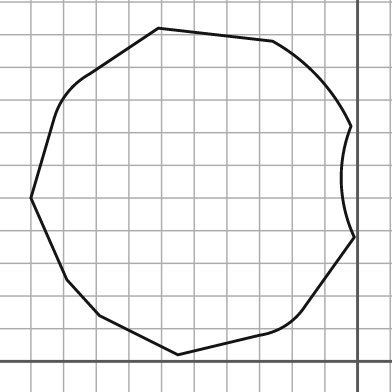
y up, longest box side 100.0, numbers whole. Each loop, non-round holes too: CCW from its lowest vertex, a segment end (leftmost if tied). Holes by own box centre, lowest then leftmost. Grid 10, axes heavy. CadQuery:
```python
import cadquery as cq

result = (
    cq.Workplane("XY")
    .moveTo(-55.0, 2.0)
    .lineTo(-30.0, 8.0)
    .threePointArc((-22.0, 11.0), (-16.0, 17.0))
    .lineTo(-1.0, 38.0)
    .threePointArc((-5.0, 55.0), (-2.0, 72.0))
    .threePointArc((-12.0, 87.0), (-26.0, 98.0))
    .lineTo(-61.0, 102.0)
    .lineTo(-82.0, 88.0)
    .threePointArc((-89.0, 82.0), (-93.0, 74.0))
    .lineTo(-100.0, 50.0)
    .lineTo(-89.0, 25.0)
    .lineTo(-79.0, 14.0)
    .close()
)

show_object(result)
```